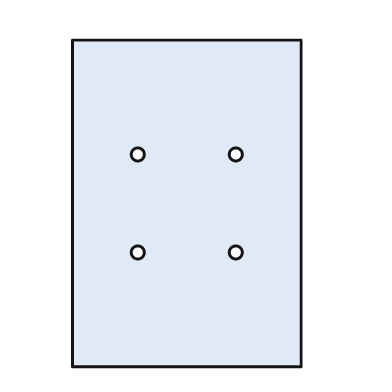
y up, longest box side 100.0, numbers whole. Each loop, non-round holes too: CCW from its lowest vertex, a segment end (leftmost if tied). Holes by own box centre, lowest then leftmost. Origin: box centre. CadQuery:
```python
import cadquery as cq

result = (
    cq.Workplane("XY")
    .moveTo(-35.0, -50.0)
    .lineTo(35.0, -50.0)
    .lineTo(35.0, 50.0)
    .lineTo(-35.0, 50.0)
    .close()
    .moveTo(-15.0, -15.0)
    .circle(2.0)
    .moveTo(15.0, -15.0)
    .circle(2.0)
    .moveTo(-15.0, 15.0)
    .circle(2.0)
    .moveTo(15.0, 15.0)
    .circle(2.0)
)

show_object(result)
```